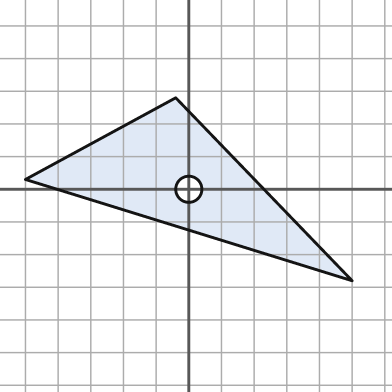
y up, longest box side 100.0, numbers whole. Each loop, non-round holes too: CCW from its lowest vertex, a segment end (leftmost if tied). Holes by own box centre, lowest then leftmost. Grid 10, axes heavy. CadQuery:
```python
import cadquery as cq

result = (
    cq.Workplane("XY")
    .moveTo(50.0, -28.0)
    .lineTo(-4.0, 28.0)
    .lineTo(-50.0, 3.0)
    .close()
    .moveTo(0.0, 0.0)
    .circle(4.0)
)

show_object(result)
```